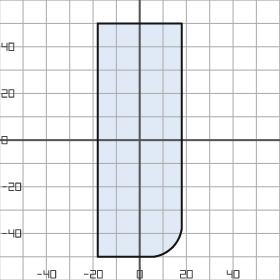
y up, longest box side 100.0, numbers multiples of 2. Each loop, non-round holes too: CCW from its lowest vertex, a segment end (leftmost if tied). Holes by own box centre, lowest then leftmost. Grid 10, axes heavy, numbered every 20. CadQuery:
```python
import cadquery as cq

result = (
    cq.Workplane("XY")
    .moveTo(-18.0, -50.0)
    .lineTo(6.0, -50.0)
    .threePointArc((14.0, -46.0), (18.0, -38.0))
    .lineTo(18.0, 50.0)
    .lineTo(-18.0, 50.0)
    .close()
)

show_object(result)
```